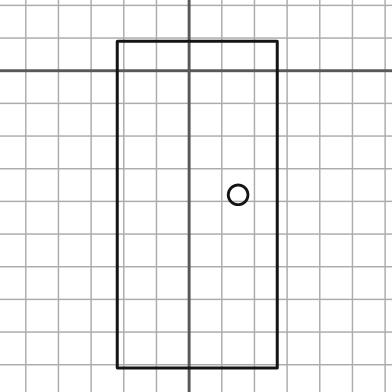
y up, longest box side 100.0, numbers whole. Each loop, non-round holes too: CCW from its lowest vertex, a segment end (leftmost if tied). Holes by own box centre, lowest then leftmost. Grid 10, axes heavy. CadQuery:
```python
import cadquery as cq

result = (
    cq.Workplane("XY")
    .moveTo(-22.0, -91.0)
    .lineTo(27.0, -91.0)
    .lineTo(27.0, 9.0)
    .lineTo(-22.0, 9.0)
    .close()
    .moveTo(15.0, -38.0)
    .circle(3.0)
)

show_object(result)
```